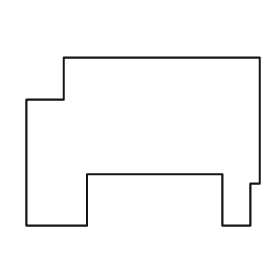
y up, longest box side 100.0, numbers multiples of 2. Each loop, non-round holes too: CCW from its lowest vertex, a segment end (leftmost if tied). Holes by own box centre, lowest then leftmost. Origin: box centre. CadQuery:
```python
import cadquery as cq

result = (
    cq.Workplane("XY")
    .moveTo(-50.0, -36.0)
    .lineTo(-24.0, -36.0)
    .lineTo(-24.0, -14.0)
    .lineTo(34.0, -14.0)
    .lineTo(34.0, -36.0)
    .lineTo(46.0, -36.0)
    .lineTo(46.0, -18.0)
    .lineTo(50.0, -18.0)
    .lineTo(50.0, 36.0)
    .lineTo(-34.0, 36.0)
    .lineTo(-34.0, 18.0)
    .lineTo(-50.0, 18.0)
    .close()
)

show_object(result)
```